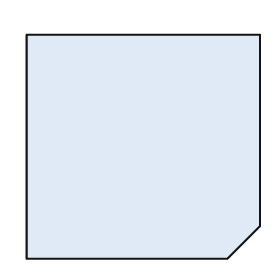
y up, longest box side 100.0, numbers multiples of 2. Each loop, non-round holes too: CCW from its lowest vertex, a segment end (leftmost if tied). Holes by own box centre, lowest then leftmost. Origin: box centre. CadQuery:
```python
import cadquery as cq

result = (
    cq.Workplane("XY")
    .moveTo(-50.0, -48.0)
    .lineTo(36.0, -48.0)
    .lineTo(50.0, -34.0)
    .lineTo(50.0, 48.0)
    .lineTo(-50.0, 48.0)
    .close()
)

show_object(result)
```